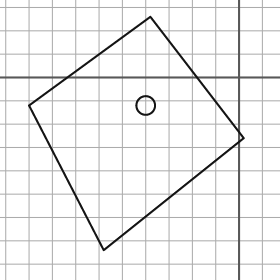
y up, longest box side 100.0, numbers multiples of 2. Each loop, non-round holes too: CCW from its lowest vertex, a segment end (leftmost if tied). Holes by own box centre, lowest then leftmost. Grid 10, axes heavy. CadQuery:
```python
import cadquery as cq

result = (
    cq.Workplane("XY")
    .moveTo(-58.0, -74.0)
    .lineTo(2.0, -26.0)
    .lineTo(-38.0, 26.0)
    .lineTo(-90.0, -12.0)
    .close()
    .moveTo(-40.0, -12.0)
    .circle(4.0)
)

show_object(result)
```